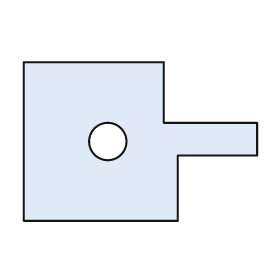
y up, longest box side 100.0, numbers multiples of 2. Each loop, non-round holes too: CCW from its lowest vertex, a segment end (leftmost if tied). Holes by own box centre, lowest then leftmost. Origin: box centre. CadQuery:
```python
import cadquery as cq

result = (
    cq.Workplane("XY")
    .moveTo(-50.0, -34.0)
    .lineTo(16.0, -34.0)
    .lineTo(16.0, -6.0)
    .lineTo(50.0, -6.0)
    .lineTo(50.0, 8.0)
    .lineTo(10.0, 8.0)
    .lineTo(10.0, 34.0)
    .lineTo(-50.0, 34.0)
    .close()
    .moveTo(-14.0, 0.0)
    .circle(8.0)
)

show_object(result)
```